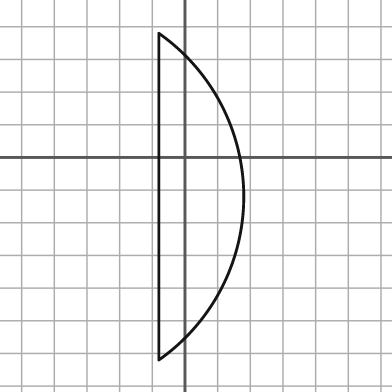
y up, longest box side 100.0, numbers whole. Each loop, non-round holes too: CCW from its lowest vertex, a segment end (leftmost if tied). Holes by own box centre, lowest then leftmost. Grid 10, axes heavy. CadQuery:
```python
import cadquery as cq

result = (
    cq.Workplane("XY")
    .moveTo(-8.0, -62.0)
    .threePointArc((18.0, -12.0), (-8.0, 38.0))
    .close()
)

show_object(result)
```